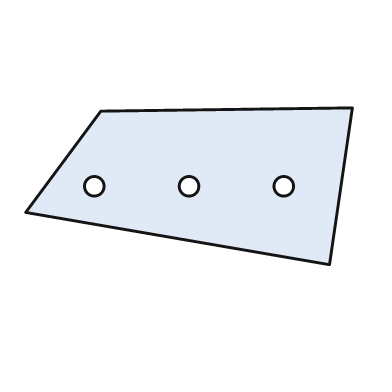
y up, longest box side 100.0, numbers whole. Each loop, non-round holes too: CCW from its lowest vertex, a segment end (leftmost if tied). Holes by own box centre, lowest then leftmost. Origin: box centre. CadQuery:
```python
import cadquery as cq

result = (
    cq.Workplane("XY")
    .moveTo(43.0, -24.0)
    .lineTo(50.0, 24.0)
    .lineTo(-27.0, 23.0)
    .lineTo(-50.0, -8.0)
    .close()
    .moveTo(-29.0, 0.0)
    .circle(3.0)
    .moveTo(0.0, 0.0)
    .circle(3.0)
    .moveTo(29.0, 0.0)
    .circle(3.0)
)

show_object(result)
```